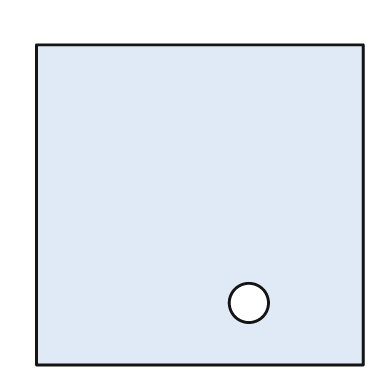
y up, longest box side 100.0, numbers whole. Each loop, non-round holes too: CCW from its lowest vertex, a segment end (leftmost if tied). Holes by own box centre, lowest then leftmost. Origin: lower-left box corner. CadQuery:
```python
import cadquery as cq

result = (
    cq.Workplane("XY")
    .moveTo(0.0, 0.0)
    .lineTo(100.0, 0.0)
    .lineTo(100.0, 98.0)
    .lineTo(0.0, 98.0)
    .close()
    .moveTo(65.0, 19.0)
    .circle(6.0)
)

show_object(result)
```